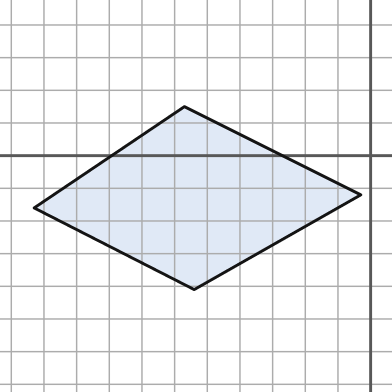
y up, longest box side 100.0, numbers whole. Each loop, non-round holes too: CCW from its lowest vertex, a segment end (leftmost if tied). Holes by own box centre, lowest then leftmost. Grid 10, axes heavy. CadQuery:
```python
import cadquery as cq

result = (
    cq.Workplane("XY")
    .moveTo(-54.0, -41.0)
    .lineTo(-3.0, -12.0)
    .lineTo(-57.0, 15.0)
    .lineTo(-103.0, -16.0)
    .close()
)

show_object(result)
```